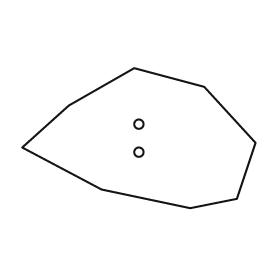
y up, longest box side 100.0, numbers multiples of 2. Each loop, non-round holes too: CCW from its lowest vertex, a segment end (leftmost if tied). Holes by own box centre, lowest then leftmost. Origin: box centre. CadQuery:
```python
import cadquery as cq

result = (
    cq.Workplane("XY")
    .moveTo(22.0, -30.0)
    .lineTo(42.0, -26.0)
    .lineTo(50.0, -2.0)
    .lineTo(28.0, 22.0)
    .lineTo(-2.0, 30.0)
    .lineTo(-30.0, 14.0)
    .lineTo(-50.0, -4.0)
    .lineTo(-16.0, -22.0)
    .close()
    .moveTo(0.0, -6.0)
    .circle(2.0)
    .moveTo(0.0, 6.0)
    .circle(2.0)
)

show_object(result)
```